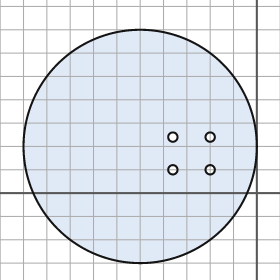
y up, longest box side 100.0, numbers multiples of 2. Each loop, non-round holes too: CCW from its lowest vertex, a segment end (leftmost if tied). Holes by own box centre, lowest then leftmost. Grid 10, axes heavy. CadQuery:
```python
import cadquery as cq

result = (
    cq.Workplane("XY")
    .moveTo(-50.0, 20.0)
    .circle(50.0)
    .moveTo(-36.0, 10.0)
    .circle(2.0)
    .moveTo(-20.0, 10.0)
    .circle(2.0)
    .moveTo(-36.0, 24.0)
    .circle(2.0)
    .moveTo(-20.0, 24.0)
    .circle(2.0)
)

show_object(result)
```